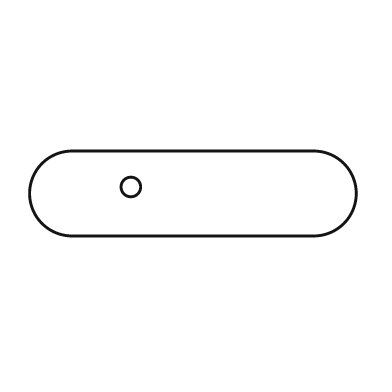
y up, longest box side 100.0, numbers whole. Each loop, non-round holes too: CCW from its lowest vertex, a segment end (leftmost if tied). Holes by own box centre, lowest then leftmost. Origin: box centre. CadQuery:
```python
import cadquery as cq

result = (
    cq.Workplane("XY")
    .moveTo(-37.0, -13.0)
    .lineTo(37.0, -13.0)
    .threePointArc((50.0, 0.0), (37.0, 13.0))
    .lineTo(-37.0, 13.0)
    .threePointArc((-50.0, 0.0), (-37.0, -13.0))
    .close()
    .moveTo(-19.0, 2.0)
    .circle(3.0)
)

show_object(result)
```